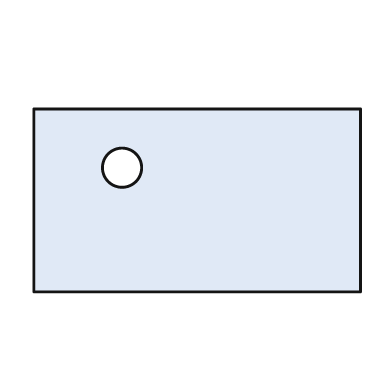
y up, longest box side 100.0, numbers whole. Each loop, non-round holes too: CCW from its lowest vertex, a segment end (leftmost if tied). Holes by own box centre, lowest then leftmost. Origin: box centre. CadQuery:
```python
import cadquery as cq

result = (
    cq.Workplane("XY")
    .moveTo(-50.0, -28.0)
    .lineTo(50.0, -28.0)
    .lineTo(50.0, 28.0)
    .lineTo(-50.0, 28.0)
    .close()
    .moveTo(-23.0, 10.0)
    .circle(6.0)
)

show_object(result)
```